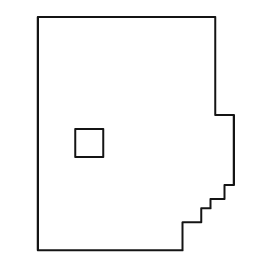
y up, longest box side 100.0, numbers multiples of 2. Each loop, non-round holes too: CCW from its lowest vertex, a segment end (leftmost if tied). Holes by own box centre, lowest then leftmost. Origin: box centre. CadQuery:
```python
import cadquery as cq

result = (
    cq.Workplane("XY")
    .moveTo(-42.0, -50.0)
    .lineTo(20.0, -50.0)
    .lineTo(20.0, -38.0)
    .lineTo(28.0, -38.0)
    .lineTo(28.0, -32.0)
    .lineTo(32.0, -32.0)
    .lineTo(32.0, -28.0)
    .lineTo(38.0, -28.0)
    .lineTo(38.0, -22.0)
    .lineTo(42.0, -22.0)
    .lineTo(42.0, 8.0)
    .lineTo(34.0, 8.0)
    .lineTo(34.0, 50.0)
    .lineTo(-42.0, 50.0)
    .close()
    .moveTo(-26.0, -10.0)
    .lineTo(-14.0, -10.0)
    .lineTo(-14.0, 2.0)
    .lineTo(-26.0, 2.0)
    .close()
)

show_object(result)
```